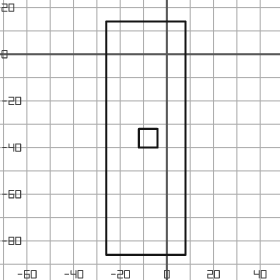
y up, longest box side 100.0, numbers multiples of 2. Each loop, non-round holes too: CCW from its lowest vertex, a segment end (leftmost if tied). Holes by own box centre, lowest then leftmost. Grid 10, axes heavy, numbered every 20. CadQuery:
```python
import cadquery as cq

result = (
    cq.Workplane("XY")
    .moveTo(-26.0, -86.0)
    .lineTo(8.0, -86.0)
    .lineTo(8.0, 14.0)
    .lineTo(-26.0, 14.0)
    .close()
    .moveTo(-12.0, -40.0)
    .lineTo(-4.0, -40.0)
    .lineTo(-4.0, -32.0)
    .lineTo(-12.0, -32.0)
    .close()
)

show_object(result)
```